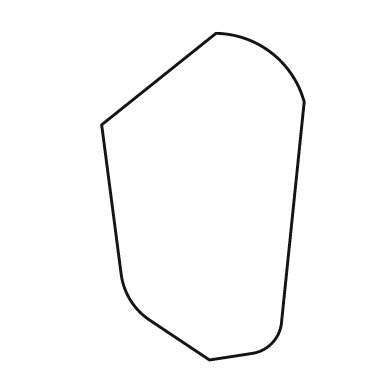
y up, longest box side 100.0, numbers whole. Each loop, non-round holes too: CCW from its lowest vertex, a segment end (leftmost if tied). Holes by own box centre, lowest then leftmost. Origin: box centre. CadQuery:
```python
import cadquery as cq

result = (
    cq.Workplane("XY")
    .moveTo(2.0, -50.0)
    .lineTo(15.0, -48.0)
    .threePointArc((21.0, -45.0), (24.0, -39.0))
    .lineTo(31.0, 29.0)
    .threePointArc((21.0, 44.0), (4.0, 50.0))
    .lineTo(-31.0, 22.0)
    .lineTo(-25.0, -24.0)
    .threePointArc((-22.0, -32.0), (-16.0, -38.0))
    .close()
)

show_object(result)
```